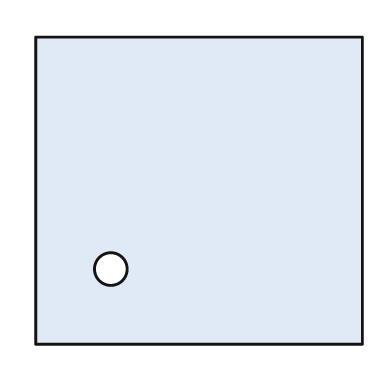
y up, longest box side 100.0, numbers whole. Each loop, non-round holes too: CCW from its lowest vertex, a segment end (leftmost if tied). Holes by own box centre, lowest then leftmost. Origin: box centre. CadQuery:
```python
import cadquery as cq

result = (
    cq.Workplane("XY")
    .moveTo(-50.0, -47.0)
    .lineTo(50.0, -47.0)
    .lineTo(50.0, 47.0)
    .lineTo(-50.0, 47.0)
    .close()
    .moveTo(-27.0, -24.0)
    .circle(5.0)
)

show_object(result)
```